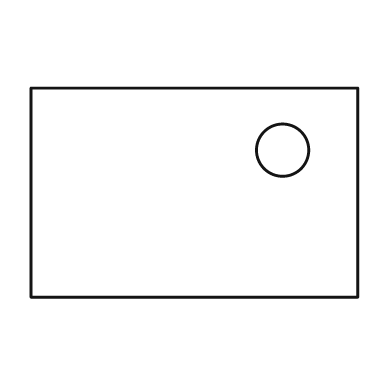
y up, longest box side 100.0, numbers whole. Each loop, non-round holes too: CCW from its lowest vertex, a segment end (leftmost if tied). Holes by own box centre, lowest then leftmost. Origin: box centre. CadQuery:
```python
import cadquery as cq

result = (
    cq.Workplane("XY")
    .moveTo(-50.0, -32.0)
    .lineTo(50.0, -32.0)
    .lineTo(50.0, 32.0)
    .lineTo(-50.0, 32.0)
    .close()
    .moveTo(27.0, 13.0)
    .circle(8.0)
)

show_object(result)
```